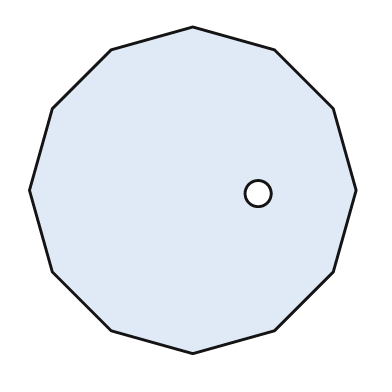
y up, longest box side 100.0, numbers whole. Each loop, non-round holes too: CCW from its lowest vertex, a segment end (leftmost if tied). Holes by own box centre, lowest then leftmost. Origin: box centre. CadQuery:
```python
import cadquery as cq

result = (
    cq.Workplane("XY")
    .moveTo(0.0, -50.0)
    .lineTo(25.0, -43.0)
    .lineTo(43.0, -25.0)
    .lineTo(50.0, 0.0)
    .lineTo(43.0, 25.0)
    .lineTo(25.0, 43.0)
    .lineTo(0.0, 50.0)
    .lineTo(-25.0, 43.0)
    .lineTo(-43.0, 25.0)
    .lineTo(-50.0, 0.0)
    .lineTo(-43.0, -25.0)
    .lineTo(-25.0, -43.0)
    .close()
    .moveTo(20.0, -1.0)
    .circle(4.0)
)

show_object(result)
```